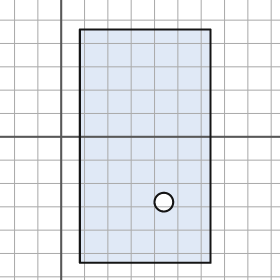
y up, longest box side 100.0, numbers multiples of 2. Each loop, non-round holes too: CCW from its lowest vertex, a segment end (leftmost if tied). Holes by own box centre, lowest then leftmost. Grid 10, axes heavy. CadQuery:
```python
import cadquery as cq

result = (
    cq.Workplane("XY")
    .moveTo(8.0, -54.0)
    .lineTo(64.0, -54.0)
    .lineTo(64.0, 46.0)
    .lineTo(8.0, 46.0)
    .close()
    .moveTo(44.0, -28.0)
    .circle(4.0)
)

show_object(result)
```